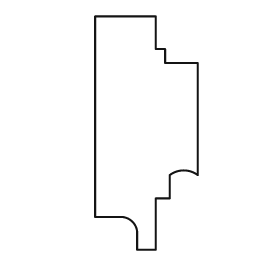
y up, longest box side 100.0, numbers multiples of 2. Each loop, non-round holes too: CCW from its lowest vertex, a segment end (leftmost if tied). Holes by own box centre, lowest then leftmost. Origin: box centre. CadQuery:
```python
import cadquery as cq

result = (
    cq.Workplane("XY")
    .moveTo(-4.0, -50.0)
    .lineTo(4.0, -50.0)
    .lineTo(4.0, -28.0)
    .lineTo(10.0, -28.0)
    .lineTo(10.0, -18.0)
    .threePointArc((16.0, -16.0), (22.0, -18.0))
    .lineTo(22.0, 30.0)
    .lineTo(8.0, 30.0)
    .lineTo(8.0, 36.0)
    .lineTo(4.0, 36.0)
    .lineTo(4.0, 50.0)
    .lineTo(-22.0, 50.0)
    .lineTo(-22.0, -36.0)
    .lineTo(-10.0, -36.0)
    .threePointArc((-6.0, -38.0), (-4.0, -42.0))
    .close()
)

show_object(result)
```